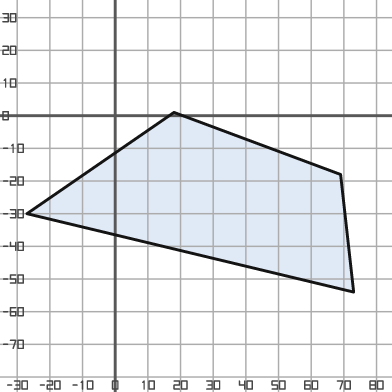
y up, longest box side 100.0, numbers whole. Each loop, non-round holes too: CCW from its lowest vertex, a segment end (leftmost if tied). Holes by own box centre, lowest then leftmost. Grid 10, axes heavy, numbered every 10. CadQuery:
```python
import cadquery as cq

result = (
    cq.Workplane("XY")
    .moveTo(73.0, -54.0)
    .lineTo(69.0, -18.0)
    .lineTo(18.0, 1.0)
    .lineTo(-27.0, -30.0)
    .close()
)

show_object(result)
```